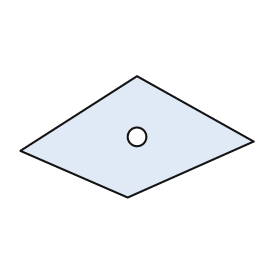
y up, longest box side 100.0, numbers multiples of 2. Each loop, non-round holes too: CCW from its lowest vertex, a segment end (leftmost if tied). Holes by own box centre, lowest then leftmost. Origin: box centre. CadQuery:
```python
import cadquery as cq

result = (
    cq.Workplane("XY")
    .moveTo(-4.0, -26.0)
    .lineTo(50.0, -2.0)
    .lineTo(0.0, 26.0)
    .lineTo(-50.0, -6.0)
    .close()
    .moveTo(0.0, 0.0)
    .circle(4.0)
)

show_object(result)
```